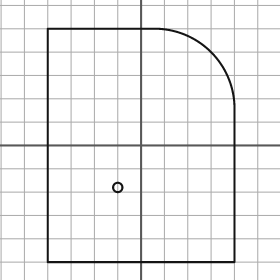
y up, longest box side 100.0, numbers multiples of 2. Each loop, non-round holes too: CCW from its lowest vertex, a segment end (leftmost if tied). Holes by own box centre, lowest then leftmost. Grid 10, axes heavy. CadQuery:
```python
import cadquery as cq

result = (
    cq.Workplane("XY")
    .moveTo(-40.0, -50.0)
    .lineTo(40.0, -50.0)
    .lineTo(40.0, 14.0)
    .threePointArc((30.0, 40.0), (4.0, 50.0))
    .lineTo(-40.0, 50.0)
    .close()
    .moveTo(-10.0, -18.0)
    .circle(2.0)
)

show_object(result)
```